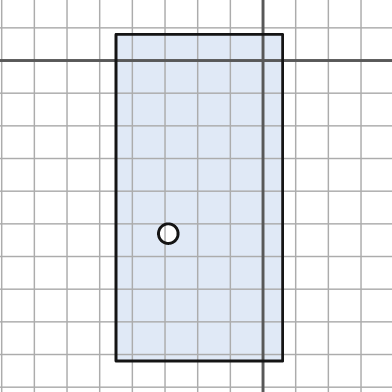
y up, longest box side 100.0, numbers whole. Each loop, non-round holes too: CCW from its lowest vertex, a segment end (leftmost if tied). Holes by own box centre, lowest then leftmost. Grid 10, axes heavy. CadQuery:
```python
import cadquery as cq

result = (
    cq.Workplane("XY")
    .moveTo(-45.0, -92.0)
    .lineTo(6.0, -92.0)
    .lineTo(6.0, 8.0)
    .lineTo(-45.0, 8.0)
    .close()
    .moveTo(-29.0, -53.0)
    .circle(3.0)
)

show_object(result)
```